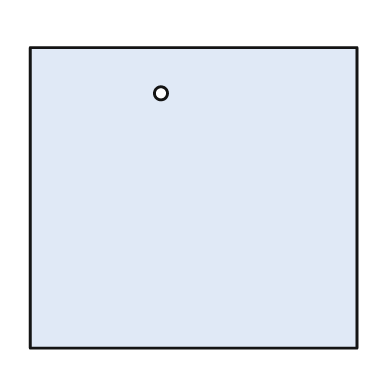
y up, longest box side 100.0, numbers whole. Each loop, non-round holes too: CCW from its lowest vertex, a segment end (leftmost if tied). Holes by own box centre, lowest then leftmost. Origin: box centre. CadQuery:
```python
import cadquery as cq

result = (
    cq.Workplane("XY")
    .moveTo(-50.0, -46.0)
    .lineTo(50.0, -46.0)
    .lineTo(50.0, 46.0)
    .lineTo(-50.0, 46.0)
    .close()
    .moveTo(-10.0, 32.0)
    .circle(2.0)
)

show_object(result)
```